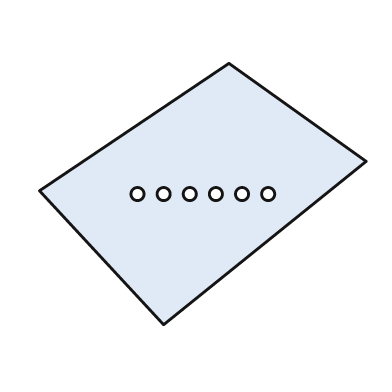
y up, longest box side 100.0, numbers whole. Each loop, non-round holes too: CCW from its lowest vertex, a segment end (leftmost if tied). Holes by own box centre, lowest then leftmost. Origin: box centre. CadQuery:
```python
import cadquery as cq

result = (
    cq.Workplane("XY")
    .moveTo(-12.0, -40.0)
    .lineTo(50.0, 10.0)
    .lineTo(8.0, 40.0)
    .lineTo(-50.0, 1.0)
    .close()
    .moveTo(-20.0, 0.0)
    .circle(2.0)
    .moveTo(-12.0, 0.0)
    .circle(2.0)
    .moveTo(-4.0, 0.0)
    .circle(2.0)
    .moveTo(4.0, 0.0)
    .circle(2.0)
    .moveTo(12.0, 0.0)
    .circle(2.0)
    .moveTo(20.0, 0.0)
    .circle(2.0)
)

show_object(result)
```